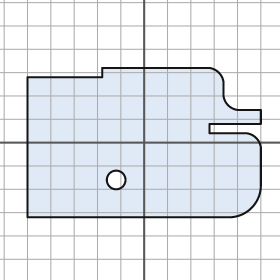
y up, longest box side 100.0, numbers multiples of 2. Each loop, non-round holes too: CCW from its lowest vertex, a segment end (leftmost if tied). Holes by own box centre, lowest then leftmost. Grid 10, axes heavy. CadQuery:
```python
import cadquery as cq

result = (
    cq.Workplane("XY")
    .moveTo(-50.0, -32.0)
    .lineTo(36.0, -32.0)
    .threePointArc((46.0, -28.0), (50.0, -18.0))
    .lineTo(50.0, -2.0)
    .threePointArc((48.0, 2.0), (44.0, 4.0))
    .lineTo(28.0, 4.0)
    .lineTo(28.0, 8.0)
    .lineTo(50.0, 8.0)
    .lineTo(50.0, 14.0)
    .lineTo(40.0, 14.0)
    .threePointArc((36.0, 16.0), (34.0, 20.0))
    .lineTo(34.0, 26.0)
    .threePointArc((32.0, 30.0), (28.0, 32.0))
    .lineTo(-18.0, 32.0)
    .lineTo(-18.0, 28.0)
    .lineTo(-50.0, 28.0)
    .close()
    .moveTo(-12.0, -16.0)
    .circle(4.0)
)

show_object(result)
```